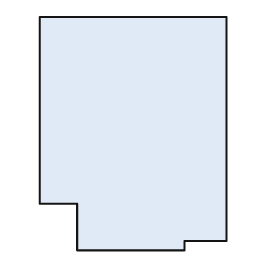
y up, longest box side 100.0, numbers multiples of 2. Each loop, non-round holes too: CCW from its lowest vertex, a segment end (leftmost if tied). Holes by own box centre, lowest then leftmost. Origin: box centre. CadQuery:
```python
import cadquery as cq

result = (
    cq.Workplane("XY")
    .moveTo(-24.0, -50.0)
    .lineTo(22.0, -50.0)
    .lineTo(22.0, -46.0)
    .lineTo(40.0, -46.0)
    .lineTo(40.0, 50.0)
    .lineTo(-40.0, 50.0)
    .lineTo(-40.0, -30.0)
    .lineTo(-24.0, -30.0)
    .close()
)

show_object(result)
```